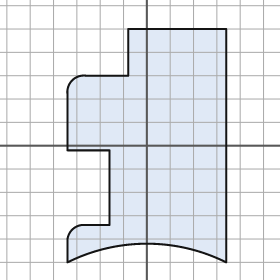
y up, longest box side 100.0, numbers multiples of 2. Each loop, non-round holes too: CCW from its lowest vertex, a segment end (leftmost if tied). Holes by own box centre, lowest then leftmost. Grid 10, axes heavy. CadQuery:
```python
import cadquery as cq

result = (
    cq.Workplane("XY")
    .moveTo(-34.0, -50.0)
    .threePointArc((0.0, -42.0), (34.0, -50.0))
    .lineTo(34.0, 50.0)
    .lineTo(-8.0, 50.0)
    .lineTo(-8.0, 30.0)
    .lineTo(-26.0, 30.0)
    .threePointArc((-32.0, 28.0), (-34.0, 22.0))
    .lineTo(-34.0, -2.0)
    .lineTo(-16.0, -2.0)
    .lineTo(-16.0, -34.0)
    .lineTo(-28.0, -34.0)
    .threePointArc((-32.0, -36.0), (-34.0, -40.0))
    .close()
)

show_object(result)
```